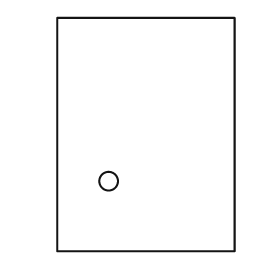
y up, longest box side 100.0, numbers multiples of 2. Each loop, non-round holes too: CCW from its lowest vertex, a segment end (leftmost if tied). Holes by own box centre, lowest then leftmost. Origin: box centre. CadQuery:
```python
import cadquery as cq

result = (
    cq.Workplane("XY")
    .moveTo(-38.0, -50.0)
    .lineTo(38.0, -50.0)
    .lineTo(38.0, 50.0)
    .lineTo(-38.0, 50.0)
    .close()
    .moveTo(-16.0, -20.0)
    .circle(4.0)
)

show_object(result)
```